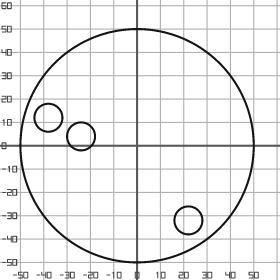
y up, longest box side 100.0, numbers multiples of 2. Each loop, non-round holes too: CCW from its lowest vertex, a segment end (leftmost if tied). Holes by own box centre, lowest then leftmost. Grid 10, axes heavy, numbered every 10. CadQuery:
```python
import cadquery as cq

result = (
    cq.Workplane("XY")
    .moveTo(0.0, 0.0)
    .circle(50.0)
    .moveTo(22.0, -32.0)
    .circle(6.0)
    .moveTo(-24.0, 4.0)
    .circle(6.0)
    .moveTo(-38.0, 12.0)
    .circle(6.0)
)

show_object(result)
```